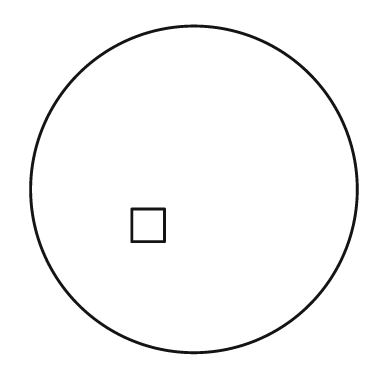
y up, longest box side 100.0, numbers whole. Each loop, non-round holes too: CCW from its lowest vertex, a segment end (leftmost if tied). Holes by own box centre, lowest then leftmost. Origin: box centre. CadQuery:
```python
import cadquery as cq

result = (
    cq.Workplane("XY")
    .moveTo(0.0, 0.0)
    .circle(50.0)
    .moveTo(-19.0, -16.0)
    .lineTo(-9.0, -16.0)
    .lineTo(-9.0, -6.0)
    .lineTo(-19.0, -6.0)
    .close()
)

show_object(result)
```